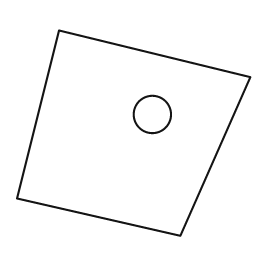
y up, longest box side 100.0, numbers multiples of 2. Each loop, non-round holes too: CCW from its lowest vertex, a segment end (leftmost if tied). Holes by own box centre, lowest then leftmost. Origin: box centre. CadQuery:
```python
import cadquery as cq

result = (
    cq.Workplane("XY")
    .moveTo(20.0, -44.0)
    .lineTo(50.0, 24.0)
    .lineTo(-32.0, 44.0)
    .lineTo(-50.0, -28.0)
    .close()
    .moveTo(8.0, 8.0)
    .circle(8.0)
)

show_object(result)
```